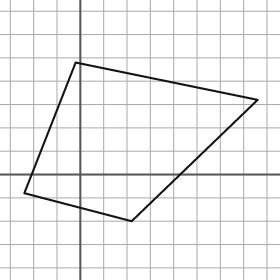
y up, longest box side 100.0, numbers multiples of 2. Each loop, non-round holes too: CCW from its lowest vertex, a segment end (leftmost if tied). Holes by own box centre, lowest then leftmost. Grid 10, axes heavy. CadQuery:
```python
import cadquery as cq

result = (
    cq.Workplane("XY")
    .moveTo(22.0, -20.0)
    .lineTo(76.0, 32.0)
    .lineTo(-2.0, 48.0)
    .lineTo(-24.0, -8.0)
    .close()
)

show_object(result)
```